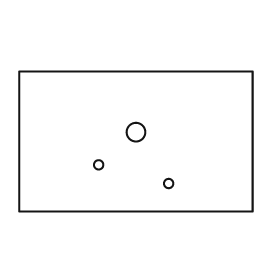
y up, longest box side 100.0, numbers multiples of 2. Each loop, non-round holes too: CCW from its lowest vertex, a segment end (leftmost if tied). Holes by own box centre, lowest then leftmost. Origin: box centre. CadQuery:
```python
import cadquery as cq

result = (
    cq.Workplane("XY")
    .moveTo(-50.0, -30.0)
    .lineTo(50.0, -30.0)
    .lineTo(50.0, 30.0)
    .lineTo(-50.0, 30.0)
    .close()
    .moveTo(14.0, -18.0)
    .circle(2.0)
    .moveTo(-16.0, -10.0)
    .circle(2.0)
    .moveTo(0.0, 4.0)
    .circle(4.0)
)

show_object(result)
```